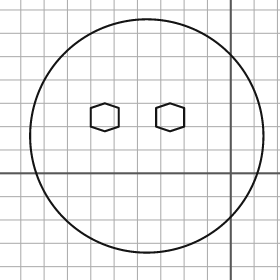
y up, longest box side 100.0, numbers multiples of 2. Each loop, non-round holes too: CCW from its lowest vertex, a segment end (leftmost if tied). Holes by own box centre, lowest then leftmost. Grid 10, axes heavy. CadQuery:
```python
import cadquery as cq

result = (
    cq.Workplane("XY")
    .moveTo(-36.0, 16.0)
    .circle(50.0)
    .moveTo(-54.0, 18.0)
    .lineTo(-48.0, 20.0)
    .lineTo(-48.0, 28.0)
    .lineTo(-54.0, 30.0)
    .lineTo(-60.0, 28.0)
    .lineTo(-60.0, 20.0)
    .close()
    .moveTo(-26.0, 18.0)
    .lineTo(-20.0, 20.0)
    .lineTo(-20.0, 28.0)
    .lineTo(-26.0, 30.0)
    .lineTo(-32.0, 28.0)
    .lineTo(-32.0, 20.0)
    .close()
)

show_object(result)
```